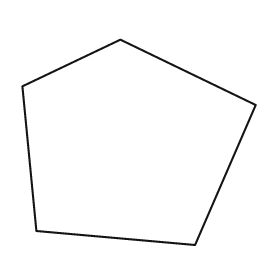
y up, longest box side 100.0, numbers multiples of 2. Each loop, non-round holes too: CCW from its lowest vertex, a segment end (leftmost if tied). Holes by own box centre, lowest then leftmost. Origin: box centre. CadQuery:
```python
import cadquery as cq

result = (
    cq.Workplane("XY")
    .moveTo(24.0, -44.0)
    .lineTo(50.0, 16.0)
    .lineTo(-8.0, 44.0)
    .lineTo(-50.0, 24.0)
    .lineTo(-44.0, -38.0)
    .close()
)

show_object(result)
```